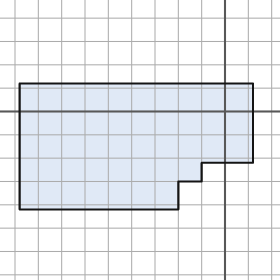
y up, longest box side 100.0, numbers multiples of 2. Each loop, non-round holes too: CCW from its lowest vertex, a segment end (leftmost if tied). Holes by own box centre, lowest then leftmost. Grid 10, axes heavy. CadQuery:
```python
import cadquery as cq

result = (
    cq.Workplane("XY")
    .moveTo(-88.0, -42.0)
    .lineTo(-20.0, -42.0)
    .lineTo(-20.0, -30.0)
    .lineTo(-10.0, -30.0)
    .lineTo(-10.0, -22.0)
    .lineTo(12.0, -22.0)
    .lineTo(12.0, 12.0)
    .lineTo(-88.0, 12.0)
    .close()
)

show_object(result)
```